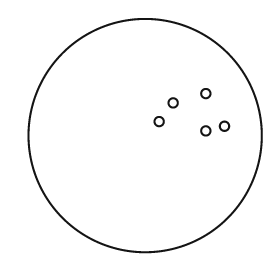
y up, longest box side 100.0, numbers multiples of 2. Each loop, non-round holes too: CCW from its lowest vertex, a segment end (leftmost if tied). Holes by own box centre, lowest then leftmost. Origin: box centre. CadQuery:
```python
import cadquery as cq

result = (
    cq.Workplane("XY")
    .moveTo(0.0, 0.0)
    .circle(50.0)
    .moveTo(26.0, 2.0)
    .circle(2.0)
    .moveTo(34.0, 4.0)
    .circle(2.0)
    .moveTo(6.0, 6.0)
    .circle(2.0)
    .moveTo(12.0, 14.0)
    .circle(2.0)
    .moveTo(26.0, 18.0)
    .circle(2.0)
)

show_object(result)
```